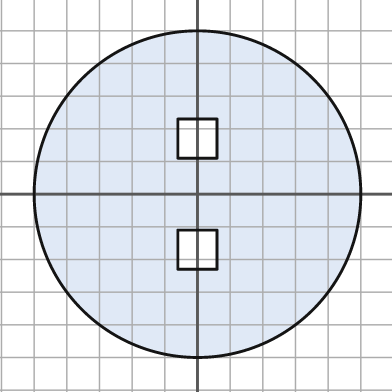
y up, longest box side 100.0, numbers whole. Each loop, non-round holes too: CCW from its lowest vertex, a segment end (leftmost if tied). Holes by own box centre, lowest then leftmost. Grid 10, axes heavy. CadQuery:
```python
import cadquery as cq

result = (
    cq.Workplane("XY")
    .moveTo(0.0, 0.0)
    .circle(50.0)
    .moveTo(-6.0, -23.0)
    .lineTo(6.0, -23.0)
    .lineTo(6.0, -11.0)
    .lineTo(-6.0, -11.0)
    .close()
    .moveTo(-6.0, 11.0)
    .lineTo(6.0, 11.0)
    .lineTo(6.0, 23.0)
    .lineTo(-6.0, 23.0)
    .close()
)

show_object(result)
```